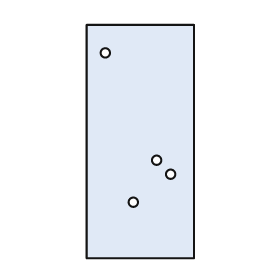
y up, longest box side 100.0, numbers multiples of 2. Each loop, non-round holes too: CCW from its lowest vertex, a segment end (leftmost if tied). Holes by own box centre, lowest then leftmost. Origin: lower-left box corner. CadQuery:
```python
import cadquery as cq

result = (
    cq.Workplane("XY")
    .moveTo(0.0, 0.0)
    .lineTo(46.0, 0.0)
    .lineTo(46.0, 100.0)
    .lineTo(0.0, 100.0)
    .close()
    .moveTo(20.0, 24.0)
    .circle(2.0)
    .moveTo(36.0, 36.0)
    .circle(2.0)
    .moveTo(30.0, 42.0)
    .circle(2.0)
    .moveTo(8.0, 88.0)
    .circle(2.0)
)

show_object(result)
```